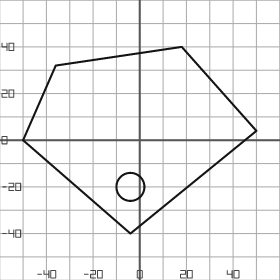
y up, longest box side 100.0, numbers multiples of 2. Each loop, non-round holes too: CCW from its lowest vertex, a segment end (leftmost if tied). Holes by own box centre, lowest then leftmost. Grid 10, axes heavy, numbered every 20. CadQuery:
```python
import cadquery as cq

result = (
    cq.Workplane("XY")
    .moveTo(-4.0, -40.0)
    .lineTo(50.0, 4.0)
    .lineTo(18.0, 40.0)
    .lineTo(-36.0, 32.0)
    .lineTo(-50.0, 0.0)
    .close()
    .moveTo(-4.0, -20.0)
    .circle(6.0)
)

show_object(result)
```